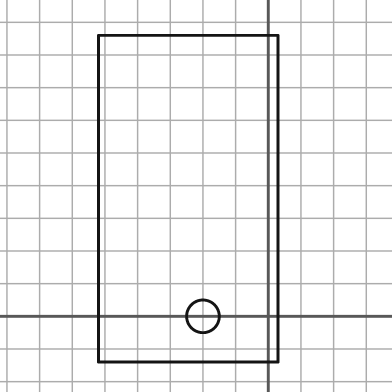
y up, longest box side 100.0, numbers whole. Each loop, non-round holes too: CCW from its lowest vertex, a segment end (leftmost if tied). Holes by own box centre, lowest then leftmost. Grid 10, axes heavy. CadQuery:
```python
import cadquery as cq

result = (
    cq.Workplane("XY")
    .moveTo(-52.0, -14.0)
    .lineTo(3.0, -14.0)
    .lineTo(3.0, 86.0)
    .lineTo(-52.0, 86.0)
    .close()
    .moveTo(-20.0, 0.0)
    .circle(5.0)
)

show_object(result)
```